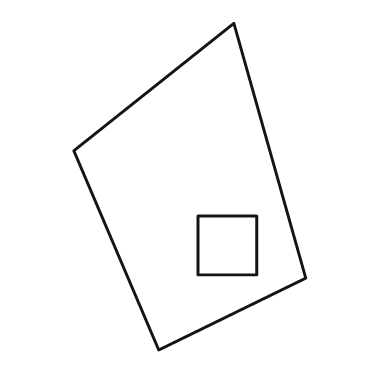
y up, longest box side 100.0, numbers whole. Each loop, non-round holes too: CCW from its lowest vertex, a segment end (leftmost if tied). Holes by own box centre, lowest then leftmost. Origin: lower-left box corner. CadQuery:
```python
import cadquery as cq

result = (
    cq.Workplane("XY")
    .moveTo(26.0, 0.0)
    .lineTo(71.0, 22.0)
    .lineTo(49.0, 100.0)
    .lineTo(0.0, 61.0)
    .close()
    .moveTo(38.0, 23.0)
    .lineTo(56.0, 23.0)
    .lineTo(56.0, 41.0)
    .lineTo(38.0, 41.0)
    .close()
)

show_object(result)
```